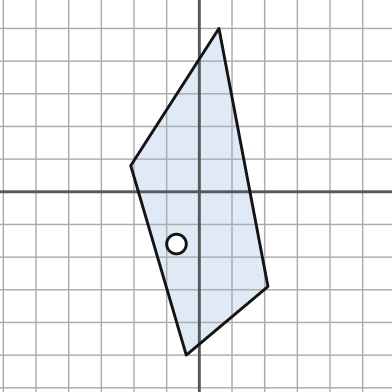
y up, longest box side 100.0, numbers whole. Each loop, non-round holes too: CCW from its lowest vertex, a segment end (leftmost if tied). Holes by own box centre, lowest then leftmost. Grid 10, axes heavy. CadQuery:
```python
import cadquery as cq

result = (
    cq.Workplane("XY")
    .moveTo(-4.0, -50.0)
    .lineTo(21.0, -29.0)
    .lineTo(6.0, 50.0)
    .lineTo(-21.0, 8.0)
    .close()
    .moveTo(-7.0, -16.0)
    .circle(3.0)
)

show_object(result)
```